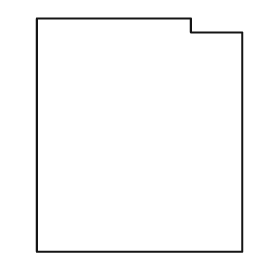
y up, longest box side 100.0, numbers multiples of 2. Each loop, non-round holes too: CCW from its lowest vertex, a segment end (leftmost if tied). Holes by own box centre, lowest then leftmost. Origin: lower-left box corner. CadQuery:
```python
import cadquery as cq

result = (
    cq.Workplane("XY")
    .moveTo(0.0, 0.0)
    .lineTo(88.0, 0.0)
    .lineTo(88.0, 94.0)
    .lineTo(66.0, 94.0)
    .lineTo(66.0, 100.0)
    .lineTo(0.0, 100.0)
    .close()
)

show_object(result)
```